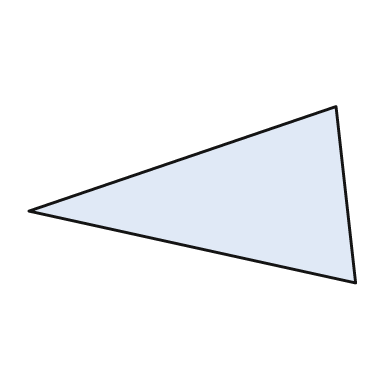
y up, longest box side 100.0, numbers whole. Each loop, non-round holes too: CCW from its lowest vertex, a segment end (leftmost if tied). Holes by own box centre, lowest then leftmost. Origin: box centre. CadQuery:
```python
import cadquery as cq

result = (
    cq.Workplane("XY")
    .moveTo(50.0, -27.0)
    .lineTo(44.0, 27.0)
    .lineTo(-50.0, -5.0)
    .close()
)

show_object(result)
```